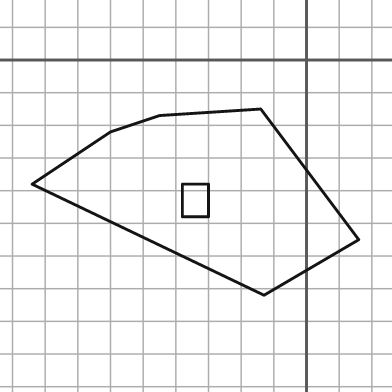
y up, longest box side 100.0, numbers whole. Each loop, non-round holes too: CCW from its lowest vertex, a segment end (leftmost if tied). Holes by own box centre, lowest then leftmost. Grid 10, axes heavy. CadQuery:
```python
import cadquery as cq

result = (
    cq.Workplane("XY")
    .moveTo(-13.0, -72.0)
    .lineTo(16.0, -55.0)
    .lineTo(-14.0, -15.0)
    .lineTo(-45.0, -17.0)
    .lineTo(-60.0, -22.0)
    .lineTo(-84.0, -38.0)
    .close()
    .moveTo(-38.0, -48.0)
    .lineTo(-30.0, -48.0)
    .lineTo(-30.0, -38.0)
    .lineTo(-38.0, -38.0)
    .close()
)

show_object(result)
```